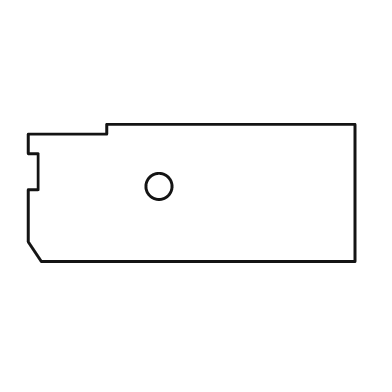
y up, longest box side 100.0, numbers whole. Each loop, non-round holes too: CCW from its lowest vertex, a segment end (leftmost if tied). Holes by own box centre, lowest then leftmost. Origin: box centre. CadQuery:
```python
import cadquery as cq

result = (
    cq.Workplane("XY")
    .moveTo(-46.0, -21.0)
    .lineTo(50.0, -21.0)
    .lineTo(50.0, 21.0)
    .lineTo(-26.0, 21.0)
    .lineTo(-26.0, 18.0)
    .lineTo(-50.0, 18.0)
    .lineTo(-50.0, 12.0)
    .lineTo(-47.0, 12.0)
    .lineTo(-47.0, 1.0)
    .lineTo(-50.0, 1.0)
    .lineTo(-50.0, -15.0)
    .close()
    .moveTo(-10.0, 2.0)
    .circle(4.0)
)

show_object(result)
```